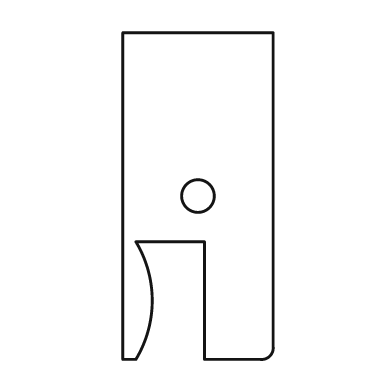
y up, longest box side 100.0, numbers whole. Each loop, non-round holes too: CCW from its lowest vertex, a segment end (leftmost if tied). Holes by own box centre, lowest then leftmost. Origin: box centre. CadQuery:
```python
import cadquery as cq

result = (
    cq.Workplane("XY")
    .moveTo(-23.0, -50.0)
    .lineTo(-19.0, -50.0)
    .threePointArc((-14.0, -32.0), (-19.0, -14.0))
    .lineTo(2.0, -14.0)
    .lineTo(2.0, -50.0)
    .lineTo(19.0, -50.0)
    .threePointArc((22.0, -49.0), (23.0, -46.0))
    .lineTo(23.0, 50.0)
    .lineTo(-23.0, 50.0)
    .close()
    .moveTo(0.0, 0.0)
    .circle(5.0)
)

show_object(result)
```